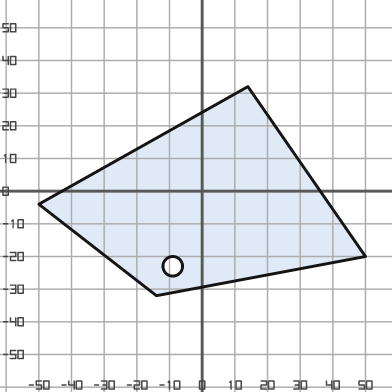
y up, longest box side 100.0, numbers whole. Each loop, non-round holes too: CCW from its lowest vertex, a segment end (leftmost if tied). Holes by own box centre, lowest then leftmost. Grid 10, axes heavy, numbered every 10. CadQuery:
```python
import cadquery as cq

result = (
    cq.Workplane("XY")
    .moveTo(-14.0, -32.0)
    .lineTo(50.0, -20.0)
    .lineTo(14.0, 32.0)
    .lineTo(-50.0, -4.0)
    .close()
    .moveTo(-9.0, -23.0)
    .circle(3.0)
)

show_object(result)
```